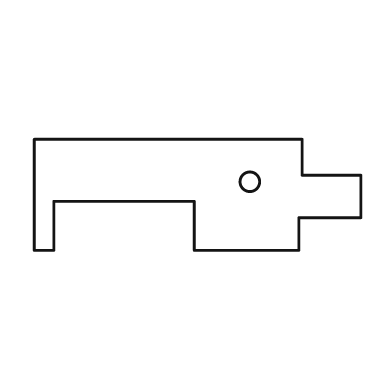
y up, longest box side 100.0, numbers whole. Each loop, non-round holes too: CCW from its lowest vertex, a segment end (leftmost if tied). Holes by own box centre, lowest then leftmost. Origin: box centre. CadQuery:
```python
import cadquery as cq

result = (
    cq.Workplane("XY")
    .moveTo(-50.0, -17.0)
    .lineTo(-44.0, -17.0)
    .lineTo(-44.0, -2.0)
    .lineTo(-1.0, -2.0)
    .lineTo(-1.0, -17.0)
    .lineTo(31.0, -17.0)
    .lineTo(31.0, -7.0)
    .lineTo(50.0, -7.0)
    .lineTo(50.0, 6.0)
    .lineTo(32.0, 6.0)
    .lineTo(32.0, 17.0)
    .lineTo(-50.0, 17.0)
    .close()
    .moveTo(16.0, 4.0)
    .circle(3.0)
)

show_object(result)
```